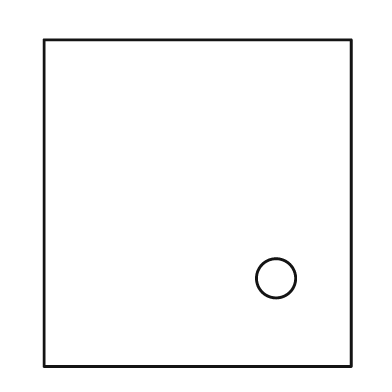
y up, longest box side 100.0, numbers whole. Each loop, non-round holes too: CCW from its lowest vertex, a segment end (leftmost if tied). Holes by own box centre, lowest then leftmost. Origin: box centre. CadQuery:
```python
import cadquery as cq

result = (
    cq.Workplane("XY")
    .moveTo(-47.0, -50.0)
    .lineTo(47.0, -50.0)
    .lineTo(47.0, 50.0)
    .lineTo(-47.0, 50.0)
    .close()
    .moveTo(24.0, -23.0)
    .circle(6.0)
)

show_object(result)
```